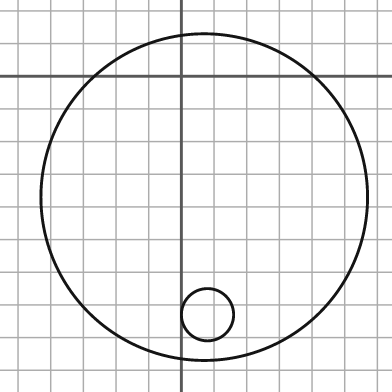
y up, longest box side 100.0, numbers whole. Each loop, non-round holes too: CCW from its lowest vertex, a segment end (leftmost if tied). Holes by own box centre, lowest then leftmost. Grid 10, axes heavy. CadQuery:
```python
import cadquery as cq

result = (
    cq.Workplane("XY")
    .moveTo(7.0, -37.0)
    .circle(50.0)
    .moveTo(8.0, -73.0)
    .circle(8.0)
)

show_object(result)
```